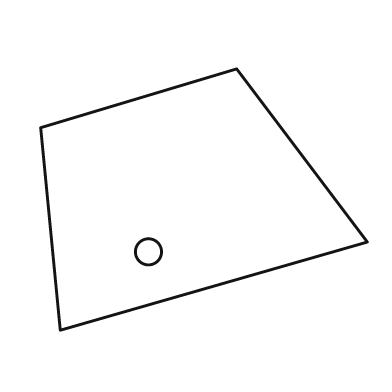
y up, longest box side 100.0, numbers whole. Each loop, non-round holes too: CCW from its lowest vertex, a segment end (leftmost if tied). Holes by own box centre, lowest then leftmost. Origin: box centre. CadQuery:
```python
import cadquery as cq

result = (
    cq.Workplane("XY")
    .moveTo(-44.0, -40.0)
    .lineTo(50.0, -13.0)
    .lineTo(10.0, 40.0)
    .lineTo(-50.0, 22.0)
    .close()
    .moveTo(-17.0, -16.0)
    .circle(4.0)
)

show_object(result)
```